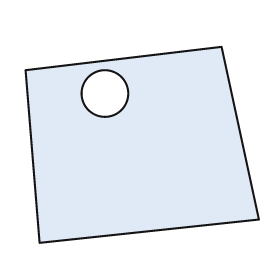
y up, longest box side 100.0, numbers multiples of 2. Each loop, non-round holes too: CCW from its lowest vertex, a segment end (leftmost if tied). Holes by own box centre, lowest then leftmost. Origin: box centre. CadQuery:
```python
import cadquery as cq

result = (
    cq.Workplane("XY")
    .moveTo(-44.0, -42.0)
    .lineTo(50.0, -32.0)
    .lineTo(34.0, 42.0)
    .lineTo(-50.0, 32.0)
    .close()
    .moveTo(-16.0, 22.0)
    .circle(10.0)
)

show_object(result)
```